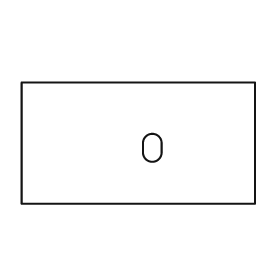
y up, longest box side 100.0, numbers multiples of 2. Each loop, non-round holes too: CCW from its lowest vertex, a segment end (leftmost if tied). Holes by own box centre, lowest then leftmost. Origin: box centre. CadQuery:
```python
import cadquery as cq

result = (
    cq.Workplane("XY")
    .moveTo(-50.0, -26.0)
    .lineTo(50.0, -26.0)
    .lineTo(50.0, 26.0)
    .lineTo(-50.0, 26.0)
    .close()
    .moveTo(2.0, -4.0)
    .threePointArc((6.0, -8.0), (10.0, -4.0))
    .lineTo(10.0, 0.0)
    .threePointArc((6.0, 4.0), (2.0, 0.0))
    .close()
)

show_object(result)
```